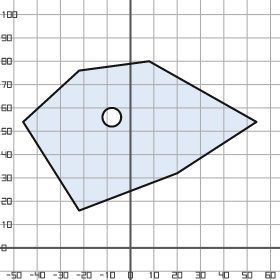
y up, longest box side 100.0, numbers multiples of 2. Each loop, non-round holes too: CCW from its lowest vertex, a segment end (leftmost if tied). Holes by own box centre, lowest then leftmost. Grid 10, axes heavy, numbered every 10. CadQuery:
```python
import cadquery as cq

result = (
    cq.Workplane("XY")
    .moveTo(-22.0, 16.0)
    .lineTo(20.0, 32.0)
    .lineTo(54.0, 54.0)
    .lineTo(8.0, 80.0)
    .lineTo(-22.0, 76.0)
    .lineTo(-46.0, 54.0)
    .close()
    .moveTo(-8.0, 56.0)
    .circle(4.0)
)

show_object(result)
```